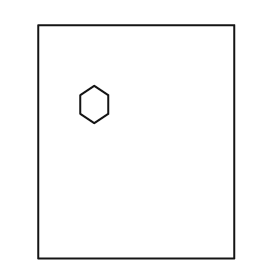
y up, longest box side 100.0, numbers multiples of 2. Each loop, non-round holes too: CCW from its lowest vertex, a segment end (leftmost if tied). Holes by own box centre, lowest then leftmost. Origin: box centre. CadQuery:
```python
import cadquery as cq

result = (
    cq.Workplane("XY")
    .moveTo(-42.0, -50.0)
    .lineTo(42.0, -50.0)
    .lineTo(42.0, 50.0)
    .lineTo(-42.0, 50.0)
    .close()
    .moveTo(-18.0, 8.0)
    .lineTo(-12.0, 12.0)
    .lineTo(-12.0, 20.0)
    .lineTo(-18.0, 24.0)
    .lineTo(-24.0, 20.0)
    .lineTo(-24.0, 12.0)
    .close()
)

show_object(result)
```